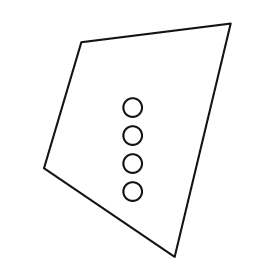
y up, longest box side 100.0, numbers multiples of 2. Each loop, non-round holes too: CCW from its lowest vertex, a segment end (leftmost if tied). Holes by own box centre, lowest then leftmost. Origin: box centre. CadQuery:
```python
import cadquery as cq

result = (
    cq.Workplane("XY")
    .moveTo(16.0, -50.0)
    .lineTo(40.0, 50.0)
    .lineTo(-24.0, 42.0)
    .lineTo(-40.0, -12.0)
    .close()
    .moveTo(-2.0, -22.0)
    .circle(4.0)
    .moveTo(-2.0, -10.0)
    .circle(4.0)
    .moveTo(-2.0, 2.0)
    .circle(4.0)
    .moveTo(-2.0, 14.0)
    .circle(4.0)
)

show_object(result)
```